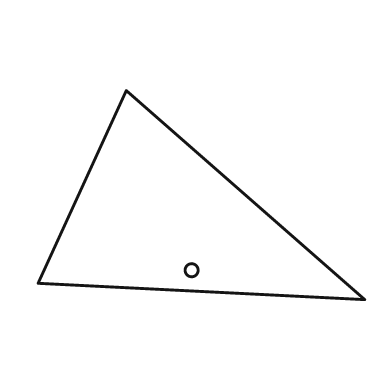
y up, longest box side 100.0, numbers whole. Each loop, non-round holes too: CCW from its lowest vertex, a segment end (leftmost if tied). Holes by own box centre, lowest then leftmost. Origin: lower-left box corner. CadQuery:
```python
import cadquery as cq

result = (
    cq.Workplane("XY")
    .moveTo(100.0, 0.0)
    .lineTo(27.0, 64.0)
    .lineTo(0.0, 5.0)
    .close()
    .moveTo(47.0, 9.0)
    .circle(2.0)
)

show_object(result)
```